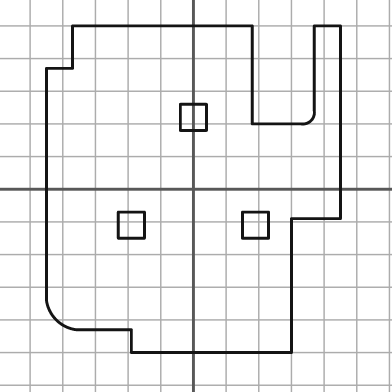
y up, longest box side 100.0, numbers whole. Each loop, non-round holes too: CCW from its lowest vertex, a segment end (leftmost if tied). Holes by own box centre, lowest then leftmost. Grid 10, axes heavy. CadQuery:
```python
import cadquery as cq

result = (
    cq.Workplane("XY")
    .moveTo(-19.0, -50.0)
    .lineTo(30.0, -50.0)
    .lineTo(30.0, -9.0)
    .lineTo(45.0, -9.0)
    .lineTo(45.0, 50.0)
    .lineTo(37.0, 50.0)
    .lineTo(37.0, 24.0)
    .threePointArc((36.0, 21.0), (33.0, 20.0))
    .lineTo(18.0, 20.0)
    .lineTo(18.0, 50.0)
    .lineTo(-37.0, 50.0)
    .lineTo(-37.0, 37.0)
    .lineTo(-45.0, 37.0)
    .lineTo(-45.0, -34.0)
    .threePointArc((-42.0, -40.0), (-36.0, -43.0))
    .lineTo(-19.0, -43.0)
    .close()
    .moveTo(-23.0, -15.0)
    .lineTo(-15.0, -15.0)
    .lineTo(-15.0, -7.0)
    .lineTo(-23.0, -7.0)
    .close()
    .moveTo(15.0, -15.0)
    .lineTo(23.0, -15.0)
    .lineTo(23.0, -7.0)
    .lineTo(15.0, -7.0)
    .close()
    .moveTo(-4.0, 18.0)
    .lineTo(4.0, 18.0)
    .lineTo(4.0, 26.0)
    .lineTo(-4.0, 26.0)
    .close()
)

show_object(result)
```